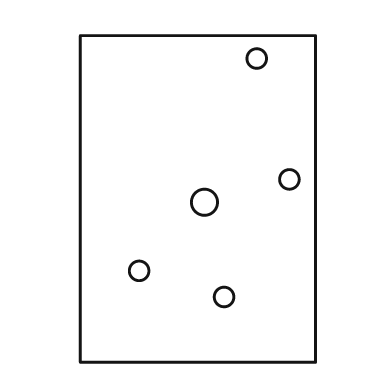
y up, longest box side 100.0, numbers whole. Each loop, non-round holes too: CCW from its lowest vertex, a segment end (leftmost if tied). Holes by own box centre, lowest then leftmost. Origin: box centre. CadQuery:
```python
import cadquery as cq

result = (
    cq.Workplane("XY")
    .moveTo(-36.0, -50.0)
    .lineTo(36.0, -50.0)
    .lineTo(36.0, 50.0)
    .lineTo(-36.0, 50.0)
    .close()
    .moveTo(8.0, -30.0)
    .circle(3.0)
    .moveTo(-18.0, -22.0)
    .circle(3.0)
    .moveTo(2.0, -1.0)
    .circle(4.0)
    .moveTo(28.0, 6.0)
    .circle(3.0)
    .moveTo(18.0, 43.0)
    .circle(3.0)
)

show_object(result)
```